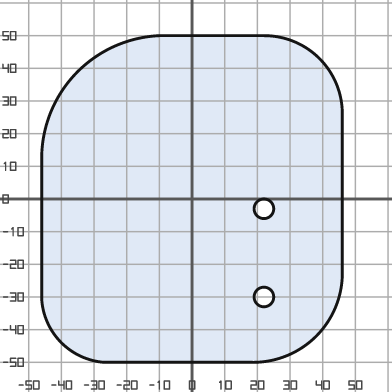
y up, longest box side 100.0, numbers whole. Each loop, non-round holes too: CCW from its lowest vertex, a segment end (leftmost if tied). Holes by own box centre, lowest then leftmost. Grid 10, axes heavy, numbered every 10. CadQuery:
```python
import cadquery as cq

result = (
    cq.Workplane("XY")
    .moveTo(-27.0, -50.0)
    .lineTo(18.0, -50.0)
    .threePointArc((38.0, -42.0), (46.0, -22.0))
    .lineTo(46.0, 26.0)
    .threePointArc((39.0, 43.0), (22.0, 50.0))
    .lineTo(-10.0, 50.0)
    .threePointArc((-35.0, 39.0), (-46.0, 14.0))
    .lineTo(-46.0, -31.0)
    .threePointArc((-40.0, -44.0), (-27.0, -50.0))
    .close()
    .moveTo(22.0, -30.0)
    .circle(3.0)
    .moveTo(22.0, -3.0)
    .circle(3.0)
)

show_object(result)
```